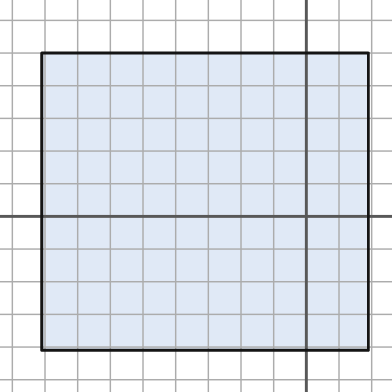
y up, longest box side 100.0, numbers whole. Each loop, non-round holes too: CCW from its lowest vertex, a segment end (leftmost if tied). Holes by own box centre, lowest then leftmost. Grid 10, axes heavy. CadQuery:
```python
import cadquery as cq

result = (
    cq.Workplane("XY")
    .moveTo(-81.0, -41.0)
    .lineTo(19.0, -41.0)
    .lineTo(19.0, 50.0)
    .lineTo(-81.0, 50.0)
    .close()
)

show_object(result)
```